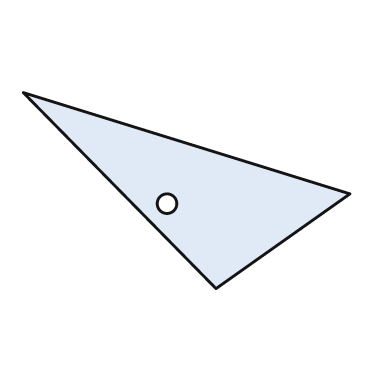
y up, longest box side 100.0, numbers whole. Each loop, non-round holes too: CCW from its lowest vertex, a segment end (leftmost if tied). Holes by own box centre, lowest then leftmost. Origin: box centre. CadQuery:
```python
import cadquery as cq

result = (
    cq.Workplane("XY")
    .moveTo(9.0, -30.0)
    .lineTo(50.0, -1.0)
    .lineTo(-50.0, 30.0)
    .close()
    .moveTo(-6.0, -4.0)
    .circle(3.0)
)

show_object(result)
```